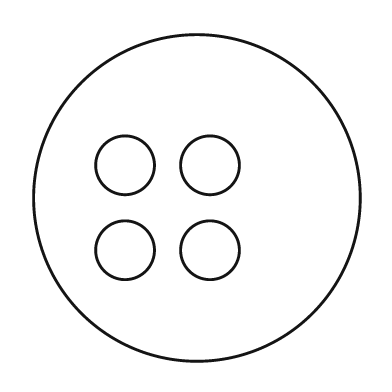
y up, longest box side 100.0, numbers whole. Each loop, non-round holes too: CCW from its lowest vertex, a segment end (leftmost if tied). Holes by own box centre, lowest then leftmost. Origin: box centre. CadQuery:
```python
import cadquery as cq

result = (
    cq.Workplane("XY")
    .moveTo(0.0, 0.0)
    .circle(50.0)
    .moveTo(-22.0, -16.0)
    .circle(9.0)
    .moveTo(4.0, -16.0)
    .circle(9.0)
    .moveTo(-22.0, 10.0)
    .circle(9.0)
    .moveTo(4.0, 10.0)
    .circle(9.0)
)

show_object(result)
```